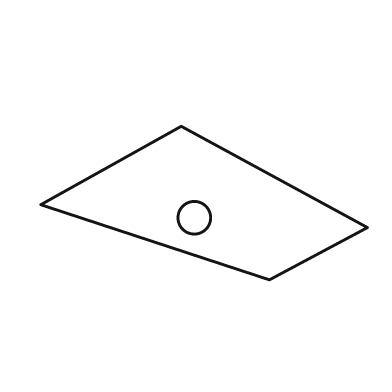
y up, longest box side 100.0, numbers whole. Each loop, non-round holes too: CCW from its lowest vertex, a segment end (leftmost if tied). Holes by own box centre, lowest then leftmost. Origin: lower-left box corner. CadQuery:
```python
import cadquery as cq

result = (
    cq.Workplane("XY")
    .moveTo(70.0, 0.0)
    .lineTo(100.0, 16.0)
    .lineTo(43.0, 47.0)
    .lineTo(0.0, 23.0)
    .close()
    .moveTo(47.0, 19.0)
    .circle(5.0)
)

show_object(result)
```